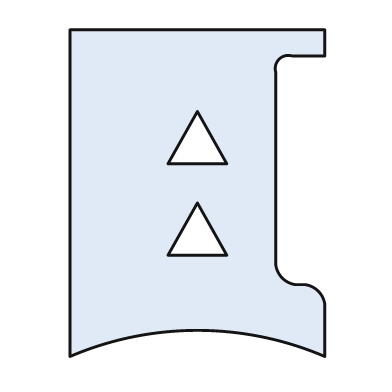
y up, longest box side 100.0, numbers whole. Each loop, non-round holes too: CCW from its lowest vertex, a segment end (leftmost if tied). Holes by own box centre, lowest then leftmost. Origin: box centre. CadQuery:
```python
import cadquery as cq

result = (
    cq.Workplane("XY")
    .moveTo(-39.0, -50.0)
    .threePointArc((0.0, -42.0), (39.0, -50.0))
    .lineTo(39.0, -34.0)
    .threePointArc((37.0, -30.0), (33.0, -28.0))
    .lineTo(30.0, -28.0)
    .threePointArc((26.0, -26.0), (24.0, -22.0))
    .lineTo(24.0, 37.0)
    .threePointArc((25.0, 41.0), (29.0, 42.0))
    .lineTo(39.0, 42.0)
    .lineTo(39.0, 50.0)
    .lineTo(-39.0, 50.0)
    .close()
    .moveTo(-9.0, -19.0)
    .lineTo(9.0, -19.0)
    .lineTo(0.0, -3.0)
    .close()
    .moveTo(-9.0, 9.0)
    .lineTo(9.0, 9.0)
    .lineTo(0.0, 25.0)
    .close()
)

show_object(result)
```